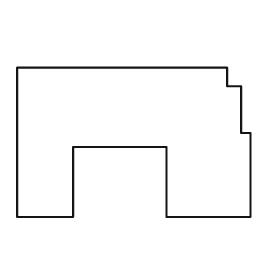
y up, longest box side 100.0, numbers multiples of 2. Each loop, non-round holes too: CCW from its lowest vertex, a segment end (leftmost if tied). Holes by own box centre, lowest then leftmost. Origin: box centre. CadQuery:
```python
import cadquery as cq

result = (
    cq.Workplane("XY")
    .moveTo(-50.0, -32.0)
    .lineTo(-26.0, -32.0)
    .lineTo(-26.0, -2.0)
    .lineTo(14.0, -2.0)
    .lineTo(14.0, -32.0)
    .lineTo(50.0, -32.0)
    .lineTo(50.0, 4.0)
    .lineTo(46.0, 4.0)
    .lineTo(46.0, 24.0)
    .lineTo(40.0, 24.0)
    .lineTo(40.0, 32.0)
    .lineTo(-50.0, 32.0)
    .close()
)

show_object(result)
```